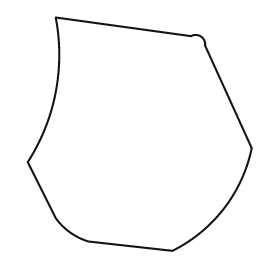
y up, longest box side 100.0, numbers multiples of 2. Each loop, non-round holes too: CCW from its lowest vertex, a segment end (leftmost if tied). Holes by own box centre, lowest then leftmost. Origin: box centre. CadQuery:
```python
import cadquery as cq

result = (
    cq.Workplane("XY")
    .moveTo(14.0, -50.0)
    .threePointArc((36.0, -32.0), (48.0, -6.0))
    .lineTo(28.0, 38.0)
    .threePointArc((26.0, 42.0), (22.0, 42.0))
    .lineTo(-36.0, 50.0)
    .threePointArc((-36.0, 18.0), (-48.0, -12.0))
    .lineTo(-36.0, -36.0)
    .threePointArc((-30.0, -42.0), (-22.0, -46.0))
    .close()
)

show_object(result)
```